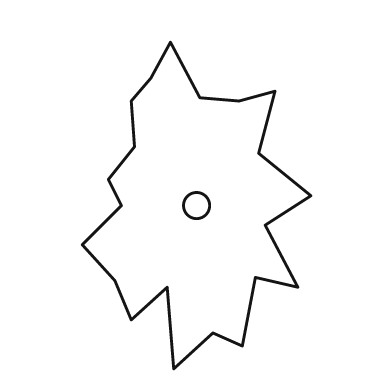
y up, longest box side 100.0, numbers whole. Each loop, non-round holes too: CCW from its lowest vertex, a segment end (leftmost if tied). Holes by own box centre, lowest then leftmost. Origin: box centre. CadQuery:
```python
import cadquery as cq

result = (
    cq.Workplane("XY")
    .moveTo(-7.0, -50.0)
    .lineTo(5.0, -39.0)
    .lineTo(14.0, -43.0)
    .lineTo(18.0, -22.0)
    .lineTo(31.0, -25.0)
    .lineTo(21.0, -6.0)
    .lineTo(35.0, 3.0)
    .lineTo(19.0, 16.0)
    .lineTo(24.0, 35.0)
    .lineTo(13.0, 32.0)
    .lineTo(1.0, 33.0)
    .lineTo(-8.0, 50.0)
    .lineTo(-14.0, 39.0)
    .lineTo(-20.0, 32.0)
    .lineTo(-19.0, 18.0)
    .lineTo(-27.0, 8.0)
    .lineTo(-23.0, 0.0)
    .lineTo(-35.0, -12.0)
    .lineTo(-25.0, -23.0)
    .lineTo(-20.0, -35.0)
    .lineTo(-9.0, -25.0)
    .close()
    .moveTo(0.0, 0.0)
    .circle(4.0)
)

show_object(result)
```